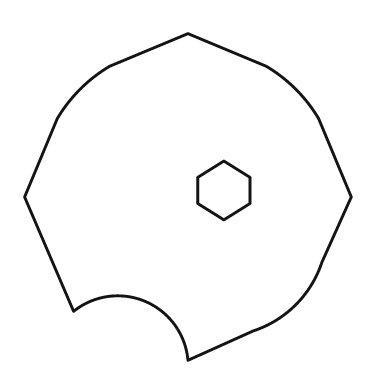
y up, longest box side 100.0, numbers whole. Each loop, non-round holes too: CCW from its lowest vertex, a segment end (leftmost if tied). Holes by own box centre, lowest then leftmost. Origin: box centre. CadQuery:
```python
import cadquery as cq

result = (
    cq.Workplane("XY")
    .moveTo(0.0, -50.0)
    .lineTo(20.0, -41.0)
    .threePointArc((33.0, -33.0), (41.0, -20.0))
    .lineTo(50.0, 0.0)
    .lineTo(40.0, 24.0)
    .threePointArc((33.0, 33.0), (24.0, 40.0))
    .lineTo(0.0, 50.0)
    .lineTo(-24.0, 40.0)
    .threePointArc((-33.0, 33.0), (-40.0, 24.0))
    .lineTo(-50.0, 0.0)
    .lineTo(-35.0, -35.0)
    .threePointArc((-13.0, -32.0), (0.0, -50.0))
    .close()
    .moveTo(11.0, -7.0)
    .lineTo(19.0, -2.0)
    .lineTo(19.0, 6.0)
    .lineTo(11.0, 11.0)
    .lineTo(3.0, 6.0)
    .lineTo(3.0, -2.0)
    .close()
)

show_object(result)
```